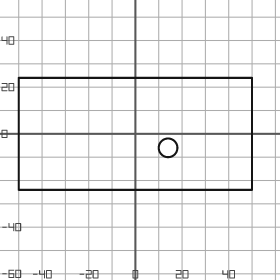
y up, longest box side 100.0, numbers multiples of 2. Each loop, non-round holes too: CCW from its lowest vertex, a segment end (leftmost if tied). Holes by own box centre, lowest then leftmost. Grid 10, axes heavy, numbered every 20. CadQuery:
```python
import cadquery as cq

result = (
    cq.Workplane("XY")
    .moveTo(-50.0, -24.0)
    .lineTo(50.0, -24.0)
    .lineTo(50.0, 24.0)
    .lineTo(-50.0, 24.0)
    .close()
    .moveTo(14.0, -6.0)
    .circle(4.0)
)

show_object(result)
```